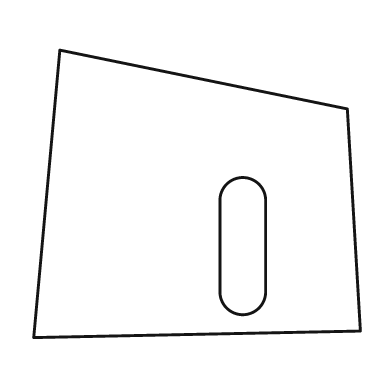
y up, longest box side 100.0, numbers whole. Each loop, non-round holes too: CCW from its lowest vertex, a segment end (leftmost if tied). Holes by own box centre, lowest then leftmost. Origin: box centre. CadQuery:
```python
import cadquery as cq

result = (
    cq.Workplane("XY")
    .moveTo(-50.0, -44.0)
    .lineTo(50.0, -42.0)
    .lineTo(46.0, 26.0)
    .lineTo(-42.0, 44.0)
    .close()
    .moveTo(7.0, -30.0)
    .threePointArc((14.0, -37.0), (21.0, -30.0))
    .lineTo(21.0, -2.0)
    .threePointArc((14.0, 5.0), (7.0, -2.0))
    .close()
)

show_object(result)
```